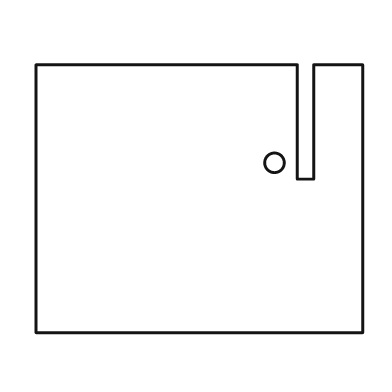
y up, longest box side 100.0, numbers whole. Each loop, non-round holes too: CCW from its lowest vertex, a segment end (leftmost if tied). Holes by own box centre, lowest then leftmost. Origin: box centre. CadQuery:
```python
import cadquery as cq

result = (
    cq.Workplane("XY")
    .moveTo(-50.0, -41.0)
    .lineTo(50.0, -41.0)
    .lineTo(50.0, 41.0)
    .lineTo(35.0, 41.0)
    .lineTo(35.0, 6.0)
    .lineTo(30.0, 6.0)
    .lineTo(30.0, 41.0)
    .lineTo(-50.0, 41.0)
    .close()
    .moveTo(23.0, 11.0)
    .circle(3.0)
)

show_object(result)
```